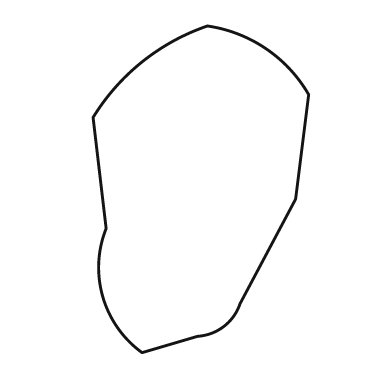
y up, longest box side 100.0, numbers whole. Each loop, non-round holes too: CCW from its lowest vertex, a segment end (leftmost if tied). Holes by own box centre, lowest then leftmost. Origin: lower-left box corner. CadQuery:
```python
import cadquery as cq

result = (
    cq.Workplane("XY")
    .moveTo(15.0, 0.0)
    .lineTo(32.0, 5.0)
    .threePointArc((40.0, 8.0), (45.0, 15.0))
    .lineTo(62.0, 47.0)
    .lineTo(66.0, 79.0)
    .threePointArc((53.0, 93.0), (35.0, 100.0))
    .threePointArc((15.0, 89.0), (0.0, 72.0))
    .lineTo(4.0, 38.0)
    .threePointArc((3.0, 17.0), (15.0, 0.0))
    .close()
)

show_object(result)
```